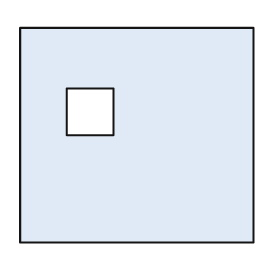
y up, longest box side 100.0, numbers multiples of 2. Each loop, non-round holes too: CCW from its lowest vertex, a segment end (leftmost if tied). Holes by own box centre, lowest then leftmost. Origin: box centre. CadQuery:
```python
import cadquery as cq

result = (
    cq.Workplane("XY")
    .moveTo(-50.0, -46.0)
    .lineTo(50.0, -46.0)
    .lineTo(50.0, 46.0)
    .lineTo(-50.0, 46.0)
    .close()
    .moveTo(-30.0, 0.0)
    .lineTo(-10.0, 0.0)
    .lineTo(-10.0, 20.0)
    .lineTo(-30.0, 20.0)
    .close()
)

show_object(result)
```